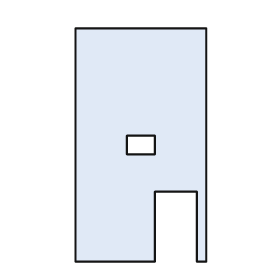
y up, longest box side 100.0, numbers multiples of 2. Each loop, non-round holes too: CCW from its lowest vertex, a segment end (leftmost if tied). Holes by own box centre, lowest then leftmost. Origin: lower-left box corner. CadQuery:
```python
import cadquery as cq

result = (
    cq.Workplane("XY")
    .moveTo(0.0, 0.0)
    .lineTo(34.0, 0.0)
    .lineTo(34.0, 30.0)
    .lineTo(52.0, 30.0)
    .lineTo(52.0, 0.0)
    .lineTo(56.0, 0.0)
    .lineTo(56.0, 100.0)
    .lineTo(0.0, 100.0)
    .close()
    .moveTo(22.0, 46.0)
    .lineTo(34.0, 46.0)
    .lineTo(34.0, 54.0)
    .lineTo(22.0, 54.0)
    .close()
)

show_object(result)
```